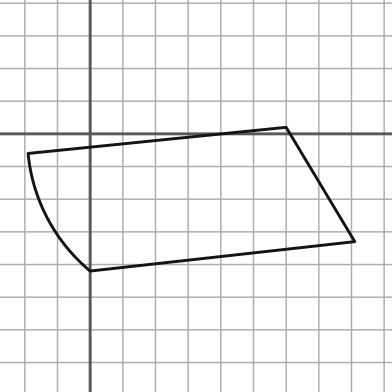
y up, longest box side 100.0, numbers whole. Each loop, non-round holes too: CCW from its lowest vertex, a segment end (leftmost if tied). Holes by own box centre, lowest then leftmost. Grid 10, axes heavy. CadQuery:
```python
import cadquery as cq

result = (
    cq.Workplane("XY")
    .moveTo(0.0, -42.0)
    .lineTo(81.0, -33.0)
    .lineTo(60.0, 2.0)
    .lineTo(-19.0, -6.0)
    .threePointArc((-13.0, -26.0), (0.0, -42.0))
    .close()
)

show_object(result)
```